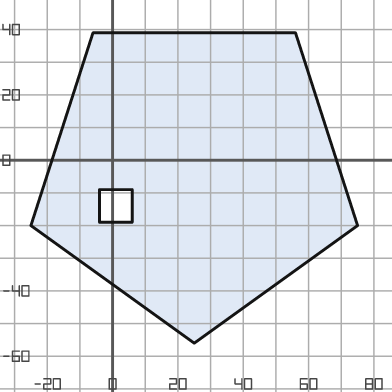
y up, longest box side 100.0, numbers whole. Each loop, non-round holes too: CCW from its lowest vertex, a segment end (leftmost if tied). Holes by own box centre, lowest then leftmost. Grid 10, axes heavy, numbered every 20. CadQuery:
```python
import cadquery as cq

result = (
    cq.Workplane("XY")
    .moveTo(25.0, -56.0)
    .lineTo(75.0, -20.0)
    .lineTo(56.0, 39.0)
    .lineTo(-6.0, 39.0)
    .lineTo(-25.0, -20.0)
    .close()
    .moveTo(-4.0, -19.0)
    .lineTo(6.0, -19.0)
    .lineTo(6.0, -9.0)
    .lineTo(-4.0, -9.0)
    .close()
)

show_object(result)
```